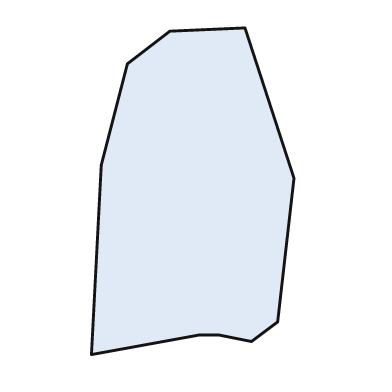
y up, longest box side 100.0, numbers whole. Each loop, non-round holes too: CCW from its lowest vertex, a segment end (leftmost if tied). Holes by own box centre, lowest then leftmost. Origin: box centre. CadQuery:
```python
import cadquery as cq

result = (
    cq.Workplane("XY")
    .moveTo(-31.0, -50.0)
    .lineTo(2.0, -44.0)
    .lineTo(8.0, -44.0)
    .lineTo(18.0, -46.0)
    .lineTo(26.0, -40.0)
    .lineTo(31.0, 4.0)
    .lineTo(16.0, 50.0)
    .lineTo(-7.0, 49.0)
    .lineTo(-20.0, 39.0)
    .lineTo(-28.0, 8.0)
    .close()
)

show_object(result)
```